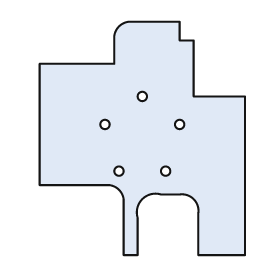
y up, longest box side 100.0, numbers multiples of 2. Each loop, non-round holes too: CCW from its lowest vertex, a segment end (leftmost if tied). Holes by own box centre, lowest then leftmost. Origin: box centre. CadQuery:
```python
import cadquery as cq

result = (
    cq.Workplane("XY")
    .moveTo(-8.0, -50.0)
    .lineTo(-2.0, -50.0)
    .lineTo(-2.0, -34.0)
    .threePointArc((0.0, -26.0), (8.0, -24.0))
    .lineTo(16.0, -24.0)
    .threePointArc((22.0, -26.0), (24.0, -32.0))
    .lineTo(24.0, -50.0)
    .lineTo(44.0, -50.0)
    .lineTo(44.0, 18.0)
    .lineTo(22.0, 18.0)
    .lineTo(22.0, 42.0)
    .lineTo(16.0, 42.0)
    .lineTo(16.0, 50.0)
    .lineTo(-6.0, 50.0)
    .threePointArc((-10.0, 48.0), (-12.0, 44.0))
    .lineTo(-12.0, 32.0)
    .lineTo(-44.0, 32.0)
    .lineTo(-44.0, -20.0)
    .lineTo(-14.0, -20.0)
    .threePointArc((-10.0, -22.0), (-8.0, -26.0))
    .close()
    .moveTo(-10.0, -14.0)
    .circle(2.0)
    .moveTo(10.0, -14.0)
    .circle(2.0)
    .moveTo(-16.0, 6.0)
    .circle(2.0)
    .moveTo(16.0, 6.0)
    .circle(2.0)
    .moveTo(0.0, 18.0)
    .circle(2.0)
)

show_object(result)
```